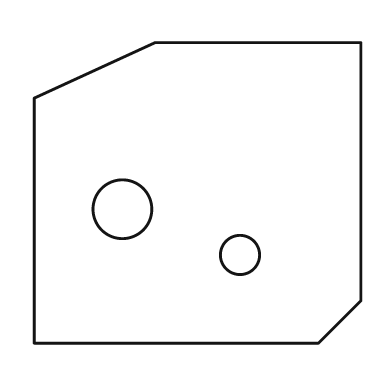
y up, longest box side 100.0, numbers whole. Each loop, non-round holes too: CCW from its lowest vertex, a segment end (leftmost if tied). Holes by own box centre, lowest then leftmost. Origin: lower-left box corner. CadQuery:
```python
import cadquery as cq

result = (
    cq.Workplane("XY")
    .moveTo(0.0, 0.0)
    .lineTo(87.0, 0.0)
    .lineTo(100.0, 13.0)
    .lineTo(100.0, 92.0)
    .lineTo(37.0, 92.0)
    .lineTo(0.0, 75.0)
    .close()
    .moveTo(63.0, 27.0)
    .circle(6.0)
    .moveTo(27.0, 41.0)
    .circle(9.0)
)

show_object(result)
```